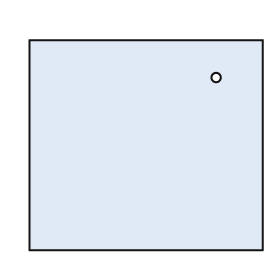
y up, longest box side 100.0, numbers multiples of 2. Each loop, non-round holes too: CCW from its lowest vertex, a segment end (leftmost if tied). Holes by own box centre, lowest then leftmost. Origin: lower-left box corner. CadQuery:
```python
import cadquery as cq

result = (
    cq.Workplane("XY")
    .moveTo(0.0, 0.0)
    .lineTo(100.0, 0.0)
    .lineTo(100.0, 90.0)
    .lineTo(0.0, 90.0)
    .close()
    .moveTo(80.0, 74.0)
    .circle(2.0)
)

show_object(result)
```